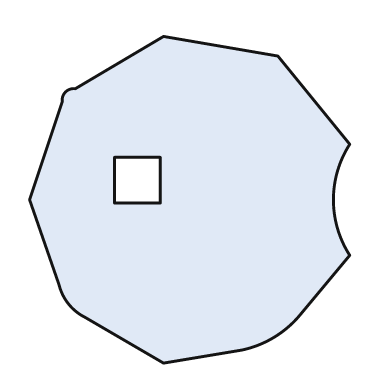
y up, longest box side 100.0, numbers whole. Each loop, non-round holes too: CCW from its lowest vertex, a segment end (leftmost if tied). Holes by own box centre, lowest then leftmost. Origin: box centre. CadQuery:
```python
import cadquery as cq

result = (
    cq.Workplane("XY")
    .moveTo(-8.0, -50.0)
    .lineTo(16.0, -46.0)
    .threePointArc((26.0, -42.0), (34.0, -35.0))
    .lineTo(49.0, -17.0)
    .threePointArc((44.0, 0.0), (49.0, 17.0))
    .lineTo(27.0, 44.0)
    .lineTo(-8.0, 50.0)
    .lineTo(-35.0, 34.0)
    .threePointArc((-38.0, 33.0), (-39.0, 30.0))
    .lineTo(-49.0, 0.0)
    .lineTo(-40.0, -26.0)
    .threePointArc((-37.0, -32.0), (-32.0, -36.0))
    .close()
    .moveTo(-23.0, -1.0)
    .lineTo(-9.0, -1.0)
    .lineTo(-9.0, 13.0)
    .lineTo(-23.0, 13.0)
    .close()
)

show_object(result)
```